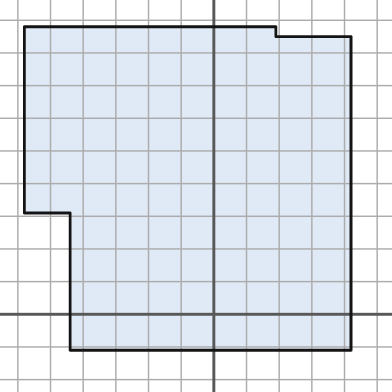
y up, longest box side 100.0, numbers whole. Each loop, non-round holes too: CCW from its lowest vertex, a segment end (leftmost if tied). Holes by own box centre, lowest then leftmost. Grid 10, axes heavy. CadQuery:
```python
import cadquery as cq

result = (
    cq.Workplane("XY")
    .moveTo(-44.0, -11.0)
    .lineTo(42.0, -11.0)
    .lineTo(42.0, 85.0)
    .lineTo(19.0, 85.0)
    .lineTo(19.0, 88.0)
    .lineTo(-58.0, 88.0)
    .lineTo(-58.0, 31.0)
    .lineTo(-44.0, 31.0)
    .close()
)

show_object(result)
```